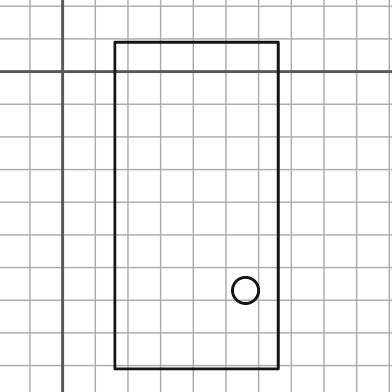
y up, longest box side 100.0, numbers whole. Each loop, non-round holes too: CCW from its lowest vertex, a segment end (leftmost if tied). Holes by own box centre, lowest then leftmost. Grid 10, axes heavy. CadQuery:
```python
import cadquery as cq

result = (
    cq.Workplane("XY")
    .moveTo(16.0, -91.0)
    .lineTo(66.0, -91.0)
    .lineTo(66.0, 9.0)
    .lineTo(16.0, 9.0)
    .close()
    .moveTo(56.0, -67.0)
    .circle(4.0)
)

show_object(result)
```